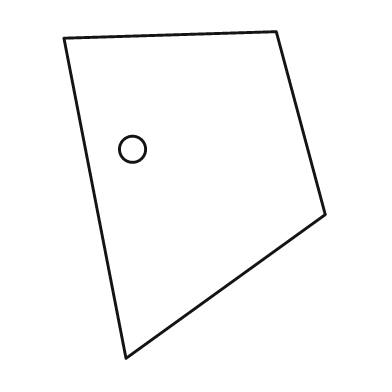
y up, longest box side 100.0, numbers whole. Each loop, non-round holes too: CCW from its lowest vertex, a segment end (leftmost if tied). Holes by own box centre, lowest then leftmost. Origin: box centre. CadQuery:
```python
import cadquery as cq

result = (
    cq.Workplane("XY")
    .moveTo(-21.0, -50.0)
    .lineTo(40.0, -6.0)
    .lineTo(25.0, 50.0)
    .lineTo(-40.0, 48.0)
    .close()
    .moveTo(-19.0, 14.0)
    .circle(4.0)
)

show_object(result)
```